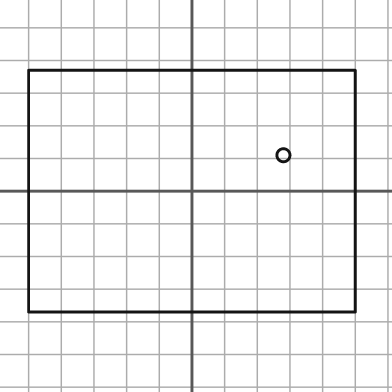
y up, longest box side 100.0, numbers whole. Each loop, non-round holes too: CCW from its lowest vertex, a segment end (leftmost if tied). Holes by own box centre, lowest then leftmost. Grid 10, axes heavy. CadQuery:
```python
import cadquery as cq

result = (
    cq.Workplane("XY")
    .moveTo(-50.0, -37.0)
    .lineTo(50.0, -37.0)
    .lineTo(50.0, 37.0)
    .lineTo(-50.0, 37.0)
    .close()
    .moveTo(28.0, 11.0)
    .circle(2.0)
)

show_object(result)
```